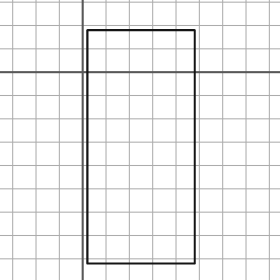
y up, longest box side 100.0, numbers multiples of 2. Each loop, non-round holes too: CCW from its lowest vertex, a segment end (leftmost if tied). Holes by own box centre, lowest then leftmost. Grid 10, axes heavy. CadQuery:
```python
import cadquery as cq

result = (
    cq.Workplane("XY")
    .moveTo(2.0, -82.0)
    .lineTo(48.0, -82.0)
    .lineTo(48.0, 18.0)
    .lineTo(2.0, 18.0)
    .close()
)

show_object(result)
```